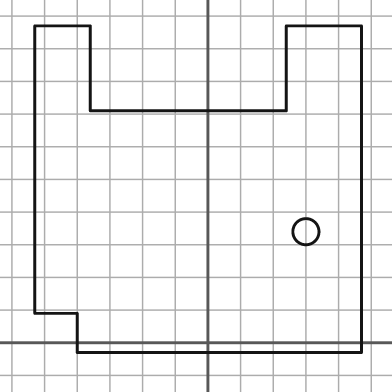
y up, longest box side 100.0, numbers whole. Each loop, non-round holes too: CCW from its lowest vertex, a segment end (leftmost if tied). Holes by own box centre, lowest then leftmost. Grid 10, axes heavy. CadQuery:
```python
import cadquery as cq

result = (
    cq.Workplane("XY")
    .moveTo(-40.0, -3.0)
    .lineTo(47.0, -3.0)
    .lineTo(47.0, 97.0)
    .lineTo(24.0, 97.0)
    .lineTo(24.0, 71.0)
    .lineTo(-36.0, 71.0)
    .lineTo(-36.0, 97.0)
    .lineTo(-53.0, 97.0)
    .lineTo(-53.0, 9.0)
    .lineTo(-40.0, 9.0)
    .close()
    .moveTo(30.0, 34.0)
    .circle(4.0)
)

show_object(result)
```